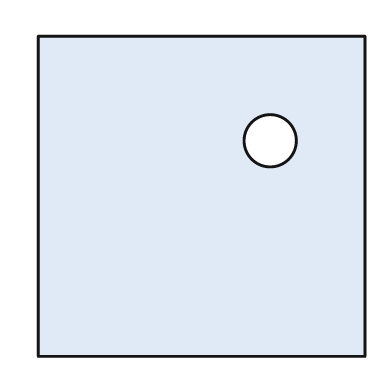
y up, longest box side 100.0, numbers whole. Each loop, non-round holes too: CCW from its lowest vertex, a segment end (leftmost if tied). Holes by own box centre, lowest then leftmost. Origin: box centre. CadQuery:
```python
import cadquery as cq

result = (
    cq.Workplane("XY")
    .moveTo(-50.0, -49.0)
    .lineTo(50.0, -49.0)
    .lineTo(50.0, 49.0)
    .lineTo(-50.0, 49.0)
    .close()
    .moveTo(21.0, 17.0)
    .circle(8.0)
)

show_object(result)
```